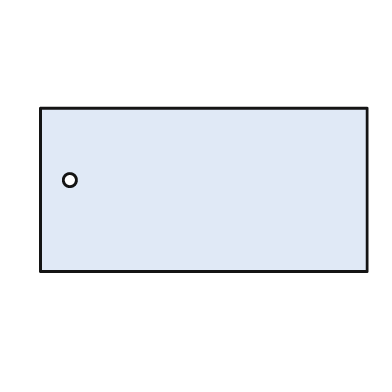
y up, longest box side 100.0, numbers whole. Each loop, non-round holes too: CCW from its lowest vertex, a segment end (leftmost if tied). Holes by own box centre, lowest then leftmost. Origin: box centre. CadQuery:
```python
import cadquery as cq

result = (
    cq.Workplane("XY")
    .moveTo(-50.0, -25.0)
    .lineTo(50.0, -25.0)
    .lineTo(50.0, 25.0)
    .lineTo(-50.0, 25.0)
    .close()
    .moveTo(-41.0, 3.0)
    .circle(2.0)
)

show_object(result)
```